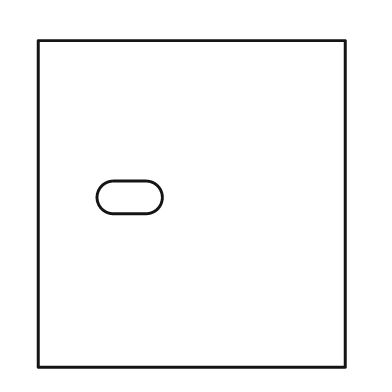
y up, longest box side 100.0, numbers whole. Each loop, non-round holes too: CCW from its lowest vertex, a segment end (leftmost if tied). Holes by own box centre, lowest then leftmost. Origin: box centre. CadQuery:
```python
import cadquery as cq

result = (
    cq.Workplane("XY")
    .moveTo(-47.0, -50.0)
    .lineTo(47.0, -50.0)
    .lineTo(47.0, 50.0)
    .lineTo(-47.0, 50.0)
    .close()
    .moveTo(-24.0, -3.0)
    .lineTo(-14.0, -3.0)
    .threePointArc((-9.0, 2.0), (-14.0, 7.0))
    .lineTo(-24.0, 7.0)
    .threePointArc((-29.0, 2.0), (-24.0, -3.0))
    .close()
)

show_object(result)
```